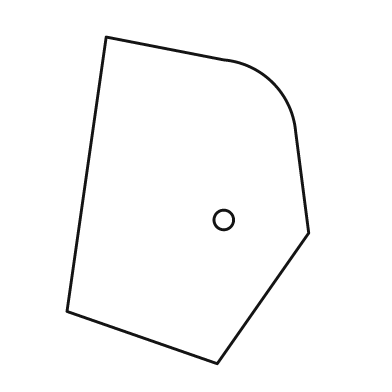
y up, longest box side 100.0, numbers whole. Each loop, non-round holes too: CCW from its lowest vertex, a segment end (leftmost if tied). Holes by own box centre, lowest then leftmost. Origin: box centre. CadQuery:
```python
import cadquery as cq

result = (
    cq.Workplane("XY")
    .moveTo(9.0, -50.0)
    .lineTo(37.0, -10.0)
    .lineTo(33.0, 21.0)
    .threePointArc((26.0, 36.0), (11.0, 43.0))
    .lineTo(-25.0, 50.0)
    .lineTo(-37.0, -34.0)
    .close()
    .moveTo(11.0, -6.0)
    .circle(3.0)
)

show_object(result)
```